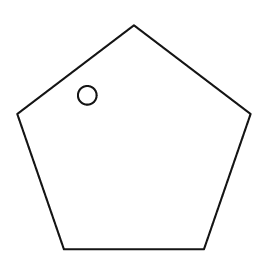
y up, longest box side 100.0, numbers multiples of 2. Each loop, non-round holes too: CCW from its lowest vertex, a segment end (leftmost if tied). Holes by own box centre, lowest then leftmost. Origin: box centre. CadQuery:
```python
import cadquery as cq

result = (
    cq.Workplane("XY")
    .moveTo(-30.0, -48.0)
    .lineTo(30.0, -48.0)
    .lineTo(50.0, 10.0)
    .lineTo(0.0, 48.0)
    .lineTo(-50.0, 10.0)
    .close()
    .moveTo(-20.0, 18.0)
    .circle(4.0)
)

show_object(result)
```